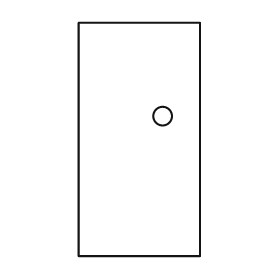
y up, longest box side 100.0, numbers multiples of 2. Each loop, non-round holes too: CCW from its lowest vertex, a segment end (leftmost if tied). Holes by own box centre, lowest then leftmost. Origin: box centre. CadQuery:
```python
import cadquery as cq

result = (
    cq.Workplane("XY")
    .moveTo(-26.0, -50.0)
    .lineTo(26.0, -50.0)
    .lineTo(26.0, 50.0)
    .lineTo(-26.0, 50.0)
    .close()
    .moveTo(10.0, 10.0)
    .circle(4.0)
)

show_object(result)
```